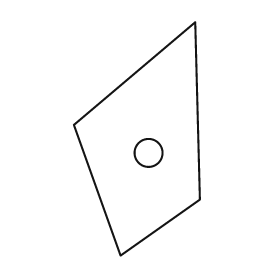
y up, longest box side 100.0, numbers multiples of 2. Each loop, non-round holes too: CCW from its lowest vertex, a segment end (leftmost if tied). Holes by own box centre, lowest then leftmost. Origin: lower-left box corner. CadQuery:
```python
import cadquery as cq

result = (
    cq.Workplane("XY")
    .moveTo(20.0, 0.0)
    .lineTo(54.0, 24.0)
    .lineTo(52.0, 100.0)
    .lineTo(0.0, 56.0)
    .close()
    .moveTo(32.0, 44.0)
    .circle(6.0)
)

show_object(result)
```